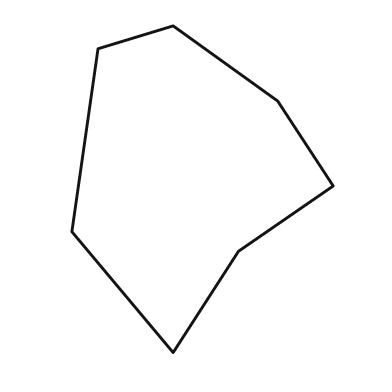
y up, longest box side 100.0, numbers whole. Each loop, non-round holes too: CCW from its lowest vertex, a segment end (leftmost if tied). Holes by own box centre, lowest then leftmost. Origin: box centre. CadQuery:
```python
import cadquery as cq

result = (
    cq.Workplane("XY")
    .moveTo(-9.0, -50.0)
    .lineTo(11.0, -19.0)
    .lineTo(40.0, 1.0)
    .lineTo(23.0, 27.0)
    .lineTo(-9.0, 50.0)
    .lineTo(-32.0, 43.0)
    .lineTo(-40.0, -13.0)
    .close()
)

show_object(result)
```